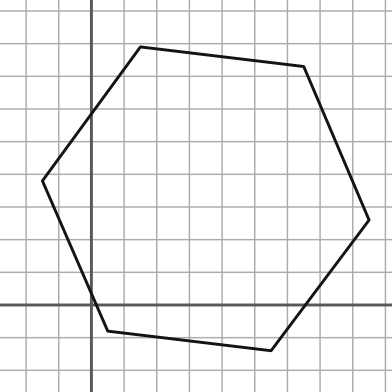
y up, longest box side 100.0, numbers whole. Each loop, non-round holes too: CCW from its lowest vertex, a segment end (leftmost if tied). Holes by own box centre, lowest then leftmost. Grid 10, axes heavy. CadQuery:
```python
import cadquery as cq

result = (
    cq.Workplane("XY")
    .moveTo(55.0, -14.0)
    .lineTo(85.0, 26.0)
    .lineTo(65.0, 73.0)
    .lineTo(15.0, 79.0)
    .lineTo(-15.0, 38.0)
    .lineTo(5.0, -8.0)
    .close()
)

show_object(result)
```